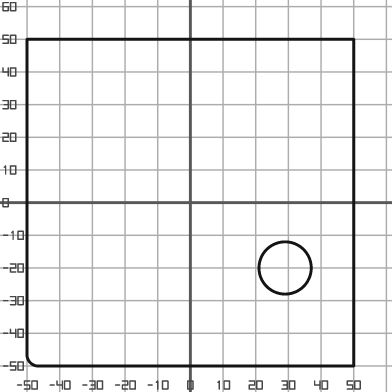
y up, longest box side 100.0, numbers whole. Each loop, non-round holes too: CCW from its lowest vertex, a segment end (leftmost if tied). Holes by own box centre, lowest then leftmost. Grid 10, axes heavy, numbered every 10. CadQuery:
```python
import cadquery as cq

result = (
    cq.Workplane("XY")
    .moveTo(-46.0, -50.0)
    .lineTo(50.0, -50.0)
    .lineTo(50.0, 50.0)
    .lineTo(-50.0, 50.0)
    .lineTo(-50.0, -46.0)
    .threePointArc((-49.0, -49.0), (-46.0, -50.0))
    .close()
    .moveTo(29.0, -20.0)
    .circle(8.0)
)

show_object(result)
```